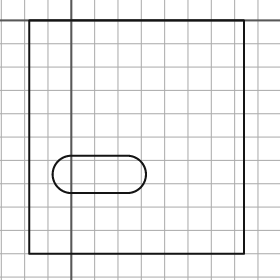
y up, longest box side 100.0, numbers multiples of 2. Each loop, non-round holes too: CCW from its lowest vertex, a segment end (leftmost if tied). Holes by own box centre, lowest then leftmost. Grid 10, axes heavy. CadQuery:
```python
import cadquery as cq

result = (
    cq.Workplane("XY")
    .moveTo(-18.0, -100.0)
    .lineTo(74.0, -100.0)
    .lineTo(74.0, 0.0)
    .lineTo(-18.0, 0.0)
    .close()
    .moveTo(0.0, -74.0)
    .lineTo(24.0, -74.0)
    .threePointArc((32.0, -66.0), (24.0, -58.0))
    .lineTo(0.0, -58.0)
    .threePointArc((-8.0, -66.0), (0.0, -74.0))
    .close()
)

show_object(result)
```